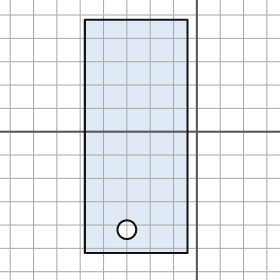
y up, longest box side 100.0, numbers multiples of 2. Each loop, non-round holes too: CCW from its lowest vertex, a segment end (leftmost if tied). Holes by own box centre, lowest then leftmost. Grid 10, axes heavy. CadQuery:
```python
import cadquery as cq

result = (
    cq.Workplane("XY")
    .moveTo(-48.0, -52.0)
    .lineTo(-4.0, -52.0)
    .lineTo(-4.0, 48.0)
    .lineTo(-48.0, 48.0)
    .close()
    .moveTo(-30.0, -42.0)
    .circle(4.0)
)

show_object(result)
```